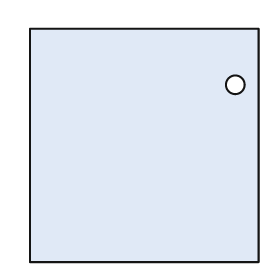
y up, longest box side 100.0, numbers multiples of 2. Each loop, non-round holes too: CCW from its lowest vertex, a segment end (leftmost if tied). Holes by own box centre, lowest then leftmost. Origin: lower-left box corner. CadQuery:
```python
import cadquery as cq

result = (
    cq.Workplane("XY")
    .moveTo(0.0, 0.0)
    .lineTo(98.0, 0.0)
    .lineTo(98.0, 100.0)
    .lineTo(0.0, 100.0)
    .close()
    .moveTo(88.0, 76.0)
    .circle(4.0)
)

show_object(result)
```